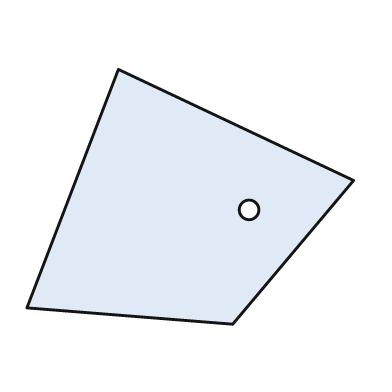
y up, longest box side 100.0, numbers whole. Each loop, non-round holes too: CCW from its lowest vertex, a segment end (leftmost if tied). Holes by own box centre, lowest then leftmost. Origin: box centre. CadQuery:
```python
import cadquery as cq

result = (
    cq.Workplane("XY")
    .moveTo(13.0, -39.0)
    .lineTo(50.0, 5.0)
    .lineTo(-22.0, 39.0)
    .lineTo(-50.0, -34.0)
    .close()
    .moveTo(18.0, -4.0)
    .circle(3.0)
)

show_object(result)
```